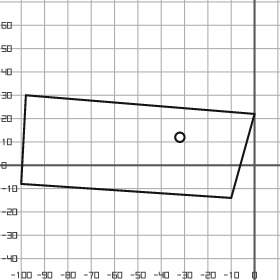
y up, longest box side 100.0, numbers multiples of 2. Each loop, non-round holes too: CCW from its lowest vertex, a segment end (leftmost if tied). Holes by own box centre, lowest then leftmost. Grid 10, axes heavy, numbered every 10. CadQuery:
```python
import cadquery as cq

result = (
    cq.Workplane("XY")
    .moveTo(-10.0, -14.0)
    .lineTo(0.0, 22.0)
    .lineTo(-98.0, 30.0)
    .lineTo(-100.0, -8.0)
    .close()
    .moveTo(-32.0, 12.0)
    .circle(2.0)
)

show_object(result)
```